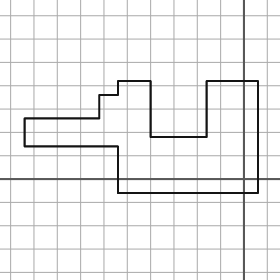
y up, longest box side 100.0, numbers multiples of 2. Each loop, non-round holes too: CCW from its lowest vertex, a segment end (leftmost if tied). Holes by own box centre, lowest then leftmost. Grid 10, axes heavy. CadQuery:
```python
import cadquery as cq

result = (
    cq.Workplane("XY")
    .moveTo(-54.0, -6.0)
    .lineTo(6.0, -6.0)
    .lineTo(6.0, 42.0)
    .lineTo(-16.0, 42.0)
    .lineTo(-16.0, 18.0)
    .lineTo(-40.0, 18.0)
    .lineTo(-40.0, 42.0)
    .lineTo(-54.0, 42.0)
    .lineTo(-54.0, 36.0)
    .lineTo(-62.0, 36.0)
    .lineTo(-62.0, 26.0)
    .lineTo(-94.0, 26.0)
    .lineTo(-94.0, 14.0)
    .lineTo(-54.0, 14.0)
    .close()
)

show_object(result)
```